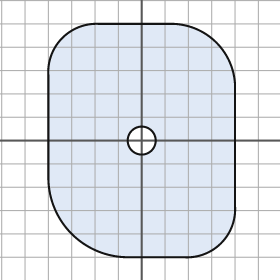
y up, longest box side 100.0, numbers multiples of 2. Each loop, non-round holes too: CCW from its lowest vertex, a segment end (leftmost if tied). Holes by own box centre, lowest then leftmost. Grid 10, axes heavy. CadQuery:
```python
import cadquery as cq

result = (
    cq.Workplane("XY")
    .moveTo(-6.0, -50.0)
    .lineTo(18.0, -50.0)
    .threePointArc((34.0, -44.0), (40.0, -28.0))
    .lineTo(40.0, 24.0)
    .threePointArc((32.0, 42.0), (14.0, 50.0))
    .lineTo(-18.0, 50.0)
    .threePointArc((-34.0, 44.0), (-40.0, 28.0))
    .lineTo(-40.0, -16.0)
    .threePointArc((-30.0, -40.0), (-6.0, -50.0))
    .close()
    .moveTo(0.0, 0.0)
    .circle(6.0)
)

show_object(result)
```